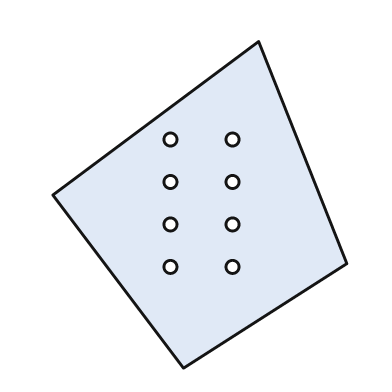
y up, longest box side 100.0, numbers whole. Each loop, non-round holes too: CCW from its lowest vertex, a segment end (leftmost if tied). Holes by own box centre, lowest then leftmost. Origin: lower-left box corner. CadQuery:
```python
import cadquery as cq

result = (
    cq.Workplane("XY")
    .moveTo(40.0, 0.0)
    .lineTo(90.0, 32.0)
    .lineTo(63.0, 100.0)
    .lineTo(0.0, 53.0)
    .close()
    .moveTo(36.0, 31.0)
    .circle(2.0)
    .moveTo(55.0, 31.0)
    .circle(2.0)
    .moveTo(36.0, 44.0)
    .circle(2.0)
    .moveTo(55.0, 44.0)
    .circle(2.0)
    .moveTo(36.0, 57.0)
    .circle(2.0)
    .moveTo(55.0, 57.0)
    .circle(2.0)
    .moveTo(36.0, 70.0)
    .circle(2.0)
    .moveTo(55.0, 70.0)
    .circle(2.0)
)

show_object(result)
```